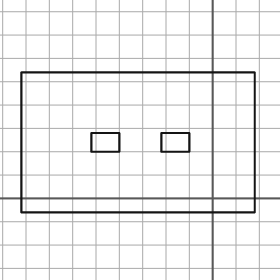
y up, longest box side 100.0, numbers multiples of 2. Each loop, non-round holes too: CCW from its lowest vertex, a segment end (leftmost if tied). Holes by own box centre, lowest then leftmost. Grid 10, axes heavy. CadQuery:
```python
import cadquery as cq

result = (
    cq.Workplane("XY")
    .moveTo(-82.0, -6.0)
    .lineTo(18.0, -6.0)
    .lineTo(18.0, 54.0)
    .lineTo(-82.0, 54.0)
    .close()
    .moveTo(-52.0, 20.0)
    .lineTo(-40.0, 20.0)
    .lineTo(-40.0, 28.0)
    .lineTo(-52.0, 28.0)
    .close()
    .moveTo(-22.0, 20.0)
    .lineTo(-10.0, 20.0)
    .lineTo(-10.0, 28.0)
    .lineTo(-22.0, 28.0)
    .close()
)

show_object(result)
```